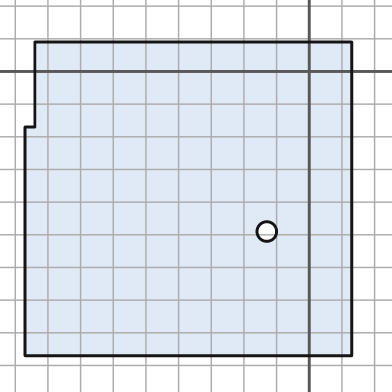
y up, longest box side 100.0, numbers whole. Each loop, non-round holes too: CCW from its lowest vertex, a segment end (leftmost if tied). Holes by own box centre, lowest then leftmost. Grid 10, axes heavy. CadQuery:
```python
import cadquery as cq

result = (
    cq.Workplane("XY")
    .moveTo(-87.0, -87.0)
    .lineTo(13.0, -87.0)
    .lineTo(13.0, 9.0)
    .lineTo(-84.0, 9.0)
    .lineTo(-84.0, -17.0)
    .lineTo(-87.0, -17.0)
    .close()
    .moveTo(-13.0, -49.0)
    .circle(3.0)
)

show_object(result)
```